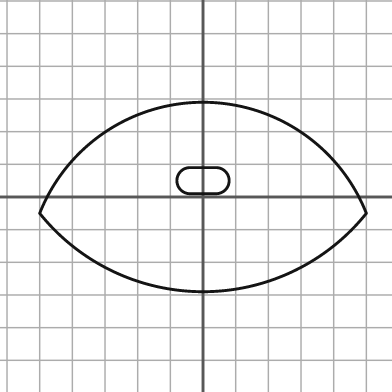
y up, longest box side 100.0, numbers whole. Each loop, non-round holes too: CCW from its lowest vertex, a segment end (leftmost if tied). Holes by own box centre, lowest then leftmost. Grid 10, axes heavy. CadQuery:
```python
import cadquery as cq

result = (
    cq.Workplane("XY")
    .moveTo(-50.0, -5.0)
    .threePointArc((0.0, -29.0), (50.0, -5.0))
    .threePointArc((0.0, 29.0), (-50.0, -5.0))
    .close()
    .moveTo(-4.0, 1.0)
    .lineTo(4.0, 1.0)
    .threePointArc((8.0, 5.0), (4.0, 9.0))
    .lineTo(-4.0, 9.0)
    .threePointArc((-8.0, 5.0), (-4.0, 1.0))
    .close()
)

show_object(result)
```